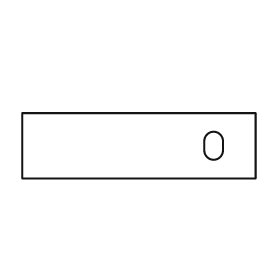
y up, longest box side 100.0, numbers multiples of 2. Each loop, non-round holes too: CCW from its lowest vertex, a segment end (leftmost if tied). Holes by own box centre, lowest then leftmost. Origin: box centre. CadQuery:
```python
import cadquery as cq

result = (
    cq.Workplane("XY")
    .moveTo(-50.0, -14.0)
    .lineTo(50.0, -14.0)
    .lineTo(50.0, 14.0)
    .lineTo(-50.0, 14.0)
    .close()
    .moveTo(28.0, -2.0)
    .threePointArc((32.0, -6.0), (36.0, -2.0))
    .lineTo(36.0, 2.0)
    .threePointArc((32.0, 6.0), (28.0, 2.0))
    .close()
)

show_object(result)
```